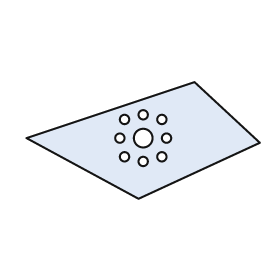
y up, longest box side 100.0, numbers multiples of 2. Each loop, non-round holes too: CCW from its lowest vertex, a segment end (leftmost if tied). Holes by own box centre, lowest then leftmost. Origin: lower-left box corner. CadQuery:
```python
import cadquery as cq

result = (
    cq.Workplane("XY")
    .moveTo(48.0, 0.0)
    .lineTo(100.0, 24.0)
    .lineTo(72.0, 50.0)
    .lineTo(0.0, 26.0)
    .close()
    .moveTo(50.0, 16.0)
    .circle(2.0)
    .moveTo(42.0, 18.0)
    .circle(2.0)
    .moveTo(58.0, 18.0)
    .circle(2.0)
    .moveTo(40.0, 26.0)
    .circle(2.0)
    .moveTo(50.0, 26.0)
    .circle(4.0)
    .moveTo(60.0, 26.0)
    .circle(2.0)
    .moveTo(42.0, 34.0)
    .circle(2.0)
    .moveTo(58.0, 34.0)
    .circle(2.0)
    .moveTo(50.0, 36.0)
    .circle(2.0)
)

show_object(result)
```